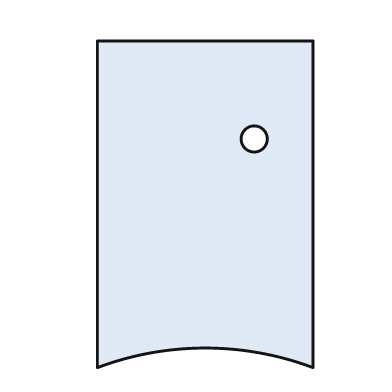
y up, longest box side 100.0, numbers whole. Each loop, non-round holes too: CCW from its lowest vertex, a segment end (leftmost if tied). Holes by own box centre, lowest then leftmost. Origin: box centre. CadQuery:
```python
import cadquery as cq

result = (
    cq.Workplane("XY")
    .moveTo(-33.0, -50.0)
    .threePointArc((0.0, -44.0), (33.0, -50.0))
    .lineTo(33.0, 50.0)
    .lineTo(-33.0, 50.0)
    .close()
    .moveTo(15.0, 20.0)
    .circle(4.0)
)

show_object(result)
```